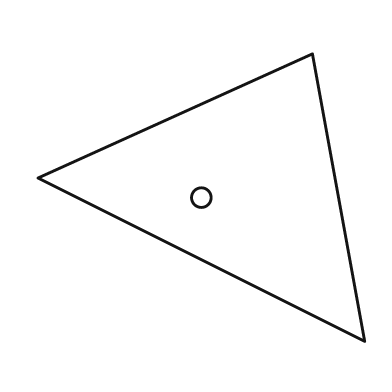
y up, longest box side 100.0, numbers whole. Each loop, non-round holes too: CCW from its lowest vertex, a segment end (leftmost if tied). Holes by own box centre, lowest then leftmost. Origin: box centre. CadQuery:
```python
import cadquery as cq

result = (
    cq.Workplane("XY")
    .moveTo(50.0, -44.0)
    .lineTo(34.0, 44.0)
    .lineTo(-50.0, 6.0)
    .close()
    .moveTo(0.0, 0.0)
    .circle(3.0)
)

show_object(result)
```